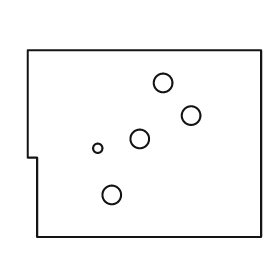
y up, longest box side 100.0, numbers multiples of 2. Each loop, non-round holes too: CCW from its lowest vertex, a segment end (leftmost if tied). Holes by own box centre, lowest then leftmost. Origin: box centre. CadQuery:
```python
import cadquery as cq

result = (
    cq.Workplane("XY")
    .moveTo(-46.0, -40.0)
    .lineTo(50.0, -40.0)
    .lineTo(50.0, 40.0)
    .lineTo(-50.0, 40.0)
    .lineTo(-50.0, -6.0)
    .lineTo(-46.0, -6.0)
    .close()
    .moveTo(-14.0, -22.0)
    .circle(4.0)
    .moveTo(-20.0, -2.0)
    .circle(2.0)
    .moveTo(-2.0, 2.0)
    .circle(4.0)
    .moveTo(20.0, 12.0)
    .circle(4.0)
    .moveTo(8.0, 26.0)
    .circle(4.0)
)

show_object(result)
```